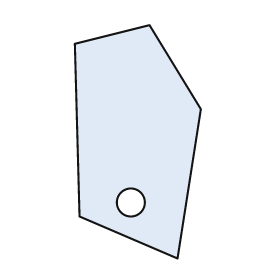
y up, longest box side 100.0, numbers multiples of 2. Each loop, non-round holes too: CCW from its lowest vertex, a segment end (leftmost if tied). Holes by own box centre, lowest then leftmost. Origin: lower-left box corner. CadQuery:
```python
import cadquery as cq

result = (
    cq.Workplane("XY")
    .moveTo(44.0, 0.0)
    .lineTo(54.0, 64.0)
    .lineTo(32.0, 100.0)
    .lineTo(0.0, 92.0)
    .lineTo(2.0, 18.0)
    .close()
    .moveTo(24.0, 24.0)
    .circle(6.0)
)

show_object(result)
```